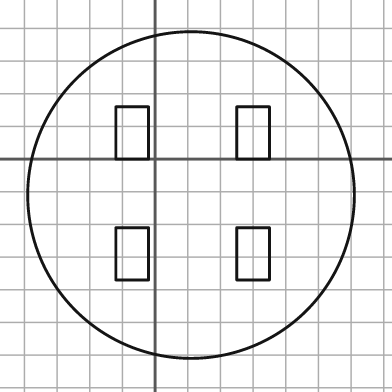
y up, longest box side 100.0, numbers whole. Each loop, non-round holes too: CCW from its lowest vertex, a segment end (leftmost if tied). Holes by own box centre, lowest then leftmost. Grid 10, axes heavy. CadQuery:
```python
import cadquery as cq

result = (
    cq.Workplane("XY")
    .moveTo(11.0, -11.0)
    .circle(50.0)
    .moveTo(-12.0, -37.0)
    .lineTo(-2.0, -37.0)
    .lineTo(-2.0, -21.0)
    .lineTo(-12.0, -21.0)
    .close()
    .moveTo(25.0, -37.0)
    .lineTo(35.0, -37.0)
    .lineTo(35.0, -21.0)
    .lineTo(25.0, -21.0)
    .close()
    .moveTo(-12.0, 0.0)
    .lineTo(-2.0, 0.0)
    .lineTo(-2.0, 16.0)
    .lineTo(-12.0, 16.0)
    .close()
    .moveTo(25.0, 0.0)
    .lineTo(35.0, 0.0)
    .lineTo(35.0, 16.0)
    .lineTo(25.0, 16.0)
    .close()
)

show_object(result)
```